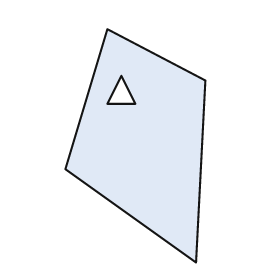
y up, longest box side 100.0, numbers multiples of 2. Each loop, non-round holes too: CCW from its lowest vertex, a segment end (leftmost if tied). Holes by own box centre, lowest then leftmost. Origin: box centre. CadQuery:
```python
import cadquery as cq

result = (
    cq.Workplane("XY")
    .moveTo(26.0, -50.0)
    .lineTo(30.0, 28.0)
    .lineTo(-12.0, 50.0)
    .lineTo(-30.0, -10.0)
    .close()
    .moveTo(-12.0, 18.0)
    .lineTo(0.0, 18.0)
    .lineTo(-6.0, 30.0)
    .close()
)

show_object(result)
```